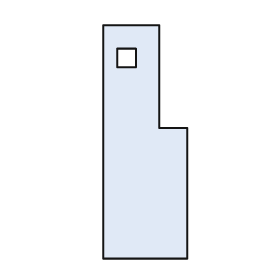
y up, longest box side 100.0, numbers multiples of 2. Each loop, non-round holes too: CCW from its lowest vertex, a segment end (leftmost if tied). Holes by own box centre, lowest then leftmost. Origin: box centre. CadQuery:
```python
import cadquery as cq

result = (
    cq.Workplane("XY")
    .moveTo(-18.0, -50.0)
    .lineTo(18.0, -50.0)
    .lineTo(18.0, 6.0)
    .lineTo(6.0, 6.0)
    .lineTo(6.0, 50.0)
    .lineTo(-18.0, 50.0)
    .close()
    .moveTo(-12.0, 32.0)
    .lineTo(-4.0, 32.0)
    .lineTo(-4.0, 40.0)
    .lineTo(-12.0, 40.0)
    .close()
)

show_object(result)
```